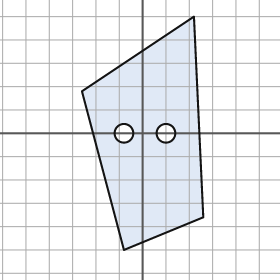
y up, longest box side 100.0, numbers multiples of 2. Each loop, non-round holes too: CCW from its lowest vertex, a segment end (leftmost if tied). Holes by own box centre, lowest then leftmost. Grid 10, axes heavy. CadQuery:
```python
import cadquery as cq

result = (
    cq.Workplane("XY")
    .moveTo(-8.0, -50.0)
    .lineTo(26.0, -36.0)
    .lineTo(22.0, 50.0)
    .lineTo(-26.0, 18.0)
    .close()
    .moveTo(-8.0, 0.0)
    .circle(4.0)
    .moveTo(10.0, 0.0)
    .circle(4.0)
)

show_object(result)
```